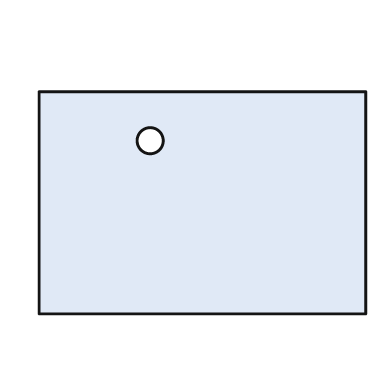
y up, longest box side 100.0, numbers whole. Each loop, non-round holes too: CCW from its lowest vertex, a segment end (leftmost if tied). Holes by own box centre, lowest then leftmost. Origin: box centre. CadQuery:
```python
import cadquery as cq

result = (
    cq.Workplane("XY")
    .moveTo(-50.0, -34.0)
    .lineTo(50.0, -34.0)
    .lineTo(50.0, 34.0)
    .lineTo(-50.0, 34.0)
    .close()
    .moveTo(-16.0, 19.0)
    .circle(4.0)
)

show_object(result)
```